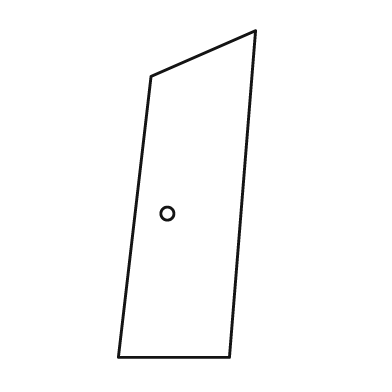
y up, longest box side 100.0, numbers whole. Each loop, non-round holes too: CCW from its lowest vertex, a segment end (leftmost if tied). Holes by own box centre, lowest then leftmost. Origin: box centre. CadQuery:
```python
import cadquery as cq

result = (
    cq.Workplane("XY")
    .moveTo(-21.0, -50.0)
    .lineTo(13.0, -50.0)
    .lineTo(21.0, 50.0)
    .lineTo(-11.0, 36.0)
    .close()
    .moveTo(-6.0, -6.0)
    .circle(2.0)
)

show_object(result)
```